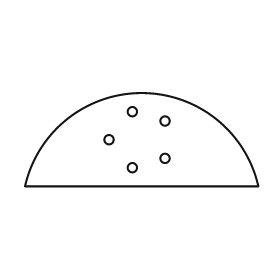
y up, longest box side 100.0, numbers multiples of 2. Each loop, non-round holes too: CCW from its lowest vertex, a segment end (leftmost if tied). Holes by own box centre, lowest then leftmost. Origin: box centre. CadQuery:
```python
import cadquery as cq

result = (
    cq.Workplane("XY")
    .moveTo(-50.0, -20.0)
    .lineTo(50.0, -20.0)
    .threePointArc((0.0, 20.0), (-50.0, -20.0))
    .close()
    .moveTo(-4.0, -12.0)
    .circle(2.0)
    .moveTo(10.0, -8.0)
    .circle(2.0)
    .moveTo(-14.0, 0.0)
    .circle(2.0)
    .moveTo(10.0, 8.0)
    .circle(2.0)
    .moveTo(-4.0, 12.0)
    .circle(2.0)
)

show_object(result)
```